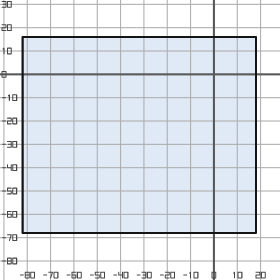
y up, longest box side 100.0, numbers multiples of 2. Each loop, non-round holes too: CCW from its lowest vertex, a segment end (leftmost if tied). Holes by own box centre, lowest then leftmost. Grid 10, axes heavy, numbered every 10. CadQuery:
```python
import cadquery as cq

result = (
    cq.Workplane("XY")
    .moveTo(-82.0, -68.0)
    .lineTo(18.0, -68.0)
    .lineTo(18.0, 16.0)
    .lineTo(-82.0, 16.0)
    .close()
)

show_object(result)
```